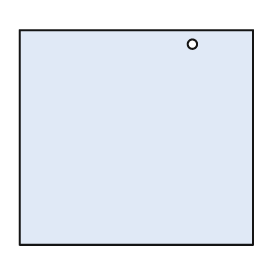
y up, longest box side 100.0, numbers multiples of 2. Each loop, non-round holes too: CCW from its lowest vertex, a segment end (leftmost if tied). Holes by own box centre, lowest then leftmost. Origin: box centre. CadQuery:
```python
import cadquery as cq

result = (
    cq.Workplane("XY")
    .moveTo(-50.0, -46.0)
    .lineTo(50.0, -46.0)
    .lineTo(50.0, 46.0)
    .lineTo(-50.0, 46.0)
    .close()
    .moveTo(24.0, 40.0)
    .circle(2.0)
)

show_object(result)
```